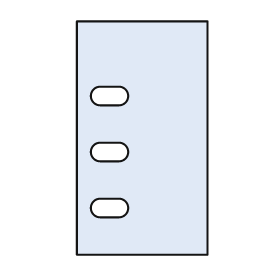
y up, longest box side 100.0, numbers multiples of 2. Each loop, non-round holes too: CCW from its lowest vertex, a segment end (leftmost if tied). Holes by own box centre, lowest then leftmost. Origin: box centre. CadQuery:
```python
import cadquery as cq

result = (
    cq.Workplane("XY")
    .moveTo(-28.0, -50.0)
    .lineTo(28.0, -50.0)
    .lineTo(28.0, 50.0)
    .lineTo(-28.0, 50.0)
    .close()
    .moveTo(-18.0, -34.0)
    .lineTo(-10.0, -34.0)
    .threePointArc((-6.0, -30.0), (-10.0, -26.0))
    .lineTo(-18.0, -26.0)
    .threePointArc((-22.0, -30.0), (-18.0, -34.0))
    .close()
    .moveTo(-18.0, -10.0)
    .lineTo(-10.0, -10.0)
    .threePointArc((-6.0, -6.0), (-10.0, -2.0))
    .lineTo(-18.0, -2.0)
    .threePointArc((-22.0, -6.0), (-18.0, -10.0))
    .close()
    .moveTo(-18.0, 14.0)
    .lineTo(-10.0, 14.0)
    .threePointArc((-6.0, 18.0), (-10.0, 22.0))
    .lineTo(-18.0, 22.0)
    .threePointArc((-22.0, 18.0), (-18.0, 14.0))
    .close()
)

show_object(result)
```